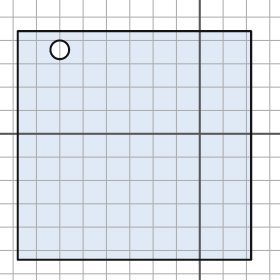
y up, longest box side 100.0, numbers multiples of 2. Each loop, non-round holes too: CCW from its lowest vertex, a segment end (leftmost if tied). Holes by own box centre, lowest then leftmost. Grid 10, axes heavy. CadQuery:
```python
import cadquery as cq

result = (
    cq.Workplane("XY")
    .moveTo(-78.0, -54.0)
    .lineTo(22.0, -54.0)
    .lineTo(22.0, 44.0)
    .lineTo(-78.0, 44.0)
    .close()
    .moveTo(-60.0, 36.0)
    .circle(4.0)
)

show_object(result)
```